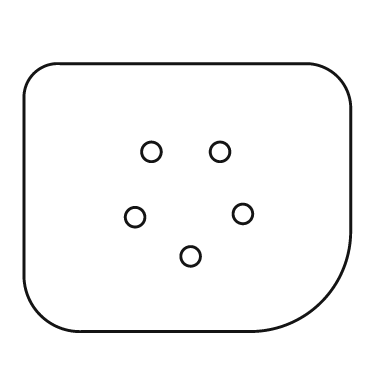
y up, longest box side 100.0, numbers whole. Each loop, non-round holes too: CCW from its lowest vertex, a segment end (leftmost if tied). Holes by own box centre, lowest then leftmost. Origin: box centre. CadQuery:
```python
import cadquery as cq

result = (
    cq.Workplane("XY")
    .moveTo(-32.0, -41.0)
    .lineTo(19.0, -41.0)
    .threePointArc((41.0, -32.0), (50.0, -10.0))
    .lineTo(50.0, 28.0)
    .threePointArc((46.0, 37.0), (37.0, 41.0))
    .lineTo(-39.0, 41.0)
    .threePointArc((-47.0, 38.0), (-50.0, 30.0))
    .lineTo(-50.0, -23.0)
    .threePointArc((-45.0, -36.0), (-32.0, -41.0))
    .close()
    .moveTo(1.0, -18.0)
    .circle(3.0)
    .moveTo(-16.0, -6.0)
    .circle(3.0)
    .moveTo(17.0, -5.0)
    .circle(3.0)
    .moveTo(-11.0, 14.0)
    .circle(3.0)
    .moveTo(10.0, 14.0)
    .circle(3.0)
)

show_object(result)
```